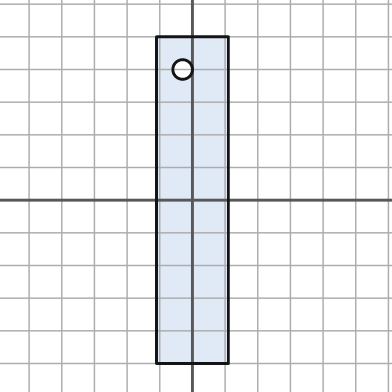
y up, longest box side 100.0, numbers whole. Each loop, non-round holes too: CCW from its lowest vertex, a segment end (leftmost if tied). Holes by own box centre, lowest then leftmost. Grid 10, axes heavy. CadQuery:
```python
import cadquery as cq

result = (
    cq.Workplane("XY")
    .moveTo(-11.0, -50.0)
    .lineTo(11.0, -50.0)
    .lineTo(11.0, 50.0)
    .lineTo(-11.0, 50.0)
    .close()
    .moveTo(-3.0, 40.0)
    .circle(3.0)
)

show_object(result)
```